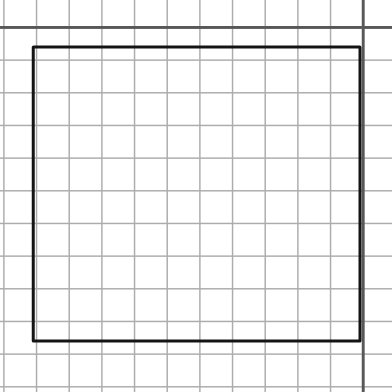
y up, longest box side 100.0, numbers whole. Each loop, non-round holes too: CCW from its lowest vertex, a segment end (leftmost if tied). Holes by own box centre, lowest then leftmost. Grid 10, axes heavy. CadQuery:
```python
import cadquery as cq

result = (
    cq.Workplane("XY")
    .moveTo(-101.0, -96.0)
    .lineTo(-1.0, -96.0)
    .lineTo(-1.0, -6.0)
    .lineTo(-101.0, -6.0)
    .close()
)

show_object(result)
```